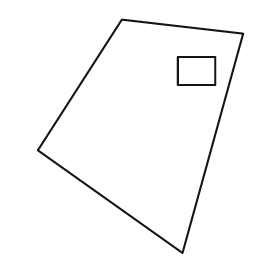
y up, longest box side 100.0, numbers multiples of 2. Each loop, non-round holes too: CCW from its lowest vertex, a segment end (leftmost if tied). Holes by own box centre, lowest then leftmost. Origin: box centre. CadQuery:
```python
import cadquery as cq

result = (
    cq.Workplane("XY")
    .moveTo(18.0, -50.0)
    .lineTo(44.0, 44.0)
    .lineTo(-8.0, 50.0)
    .lineTo(-44.0, -6.0)
    .close()
    .moveTo(16.0, 22.0)
    .lineTo(32.0, 22.0)
    .lineTo(32.0, 34.0)
    .lineTo(16.0, 34.0)
    .close()
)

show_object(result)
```